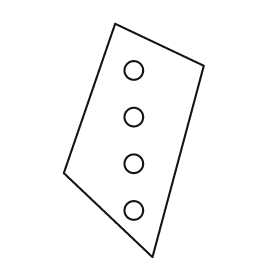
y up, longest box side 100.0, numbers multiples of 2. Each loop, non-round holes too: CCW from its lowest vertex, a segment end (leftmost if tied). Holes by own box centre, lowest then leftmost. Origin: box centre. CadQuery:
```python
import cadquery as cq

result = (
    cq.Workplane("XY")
    .moveTo(8.0, -50.0)
    .lineTo(30.0, 32.0)
    .lineTo(-8.0, 50.0)
    .lineTo(-30.0, -14.0)
    .close()
    .moveTo(0.0, -30.0)
    .circle(4.0)
    .moveTo(0.0, -10.0)
    .circle(4.0)
    .moveTo(0.0, 10.0)
    .circle(4.0)
    .moveTo(0.0, 30.0)
    .circle(4.0)
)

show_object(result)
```